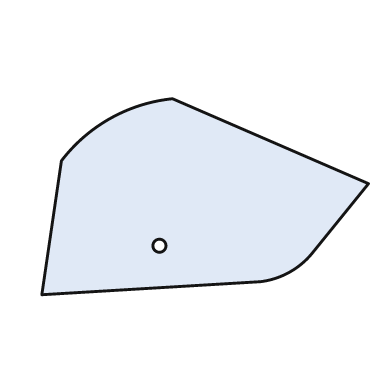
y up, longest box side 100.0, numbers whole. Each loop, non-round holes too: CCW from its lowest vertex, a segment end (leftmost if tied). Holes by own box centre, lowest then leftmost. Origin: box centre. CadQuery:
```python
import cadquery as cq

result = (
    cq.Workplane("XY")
    .moveTo(-50.0, -30.0)
    .lineTo(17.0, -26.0)
    .threePointArc((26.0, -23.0), (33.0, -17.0))
    .lineTo(50.0, 4.0)
    .lineTo(-10.0, 30.0)
    .threePointArc((-29.0, 24.0), (-44.0, 11.0))
    .close()
    .moveTo(-14.0, -15.0)
    .circle(2.0)
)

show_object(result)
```